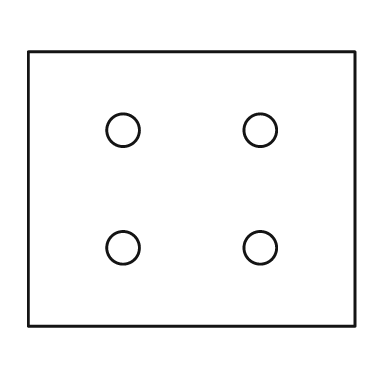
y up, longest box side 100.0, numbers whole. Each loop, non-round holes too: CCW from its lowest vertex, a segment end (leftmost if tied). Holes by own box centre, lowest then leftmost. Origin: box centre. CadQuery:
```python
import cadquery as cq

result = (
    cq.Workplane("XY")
    .moveTo(-50.0, -42.0)
    .lineTo(50.0, -42.0)
    .lineTo(50.0, 42.0)
    .lineTo(-50.0, 42.0)
    .close()
    .moveTo(-21.0, -18.0)
    .circle(5.0)
    .moveTo(21.0, -18.0)
    .circle(5.0)
    .moveTo(-21.0, 18.0)
    .circle(5.0)
    .moveTo(21.0, 18.0)
    .circle(5.0)
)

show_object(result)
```